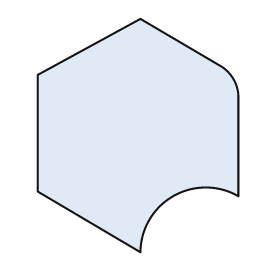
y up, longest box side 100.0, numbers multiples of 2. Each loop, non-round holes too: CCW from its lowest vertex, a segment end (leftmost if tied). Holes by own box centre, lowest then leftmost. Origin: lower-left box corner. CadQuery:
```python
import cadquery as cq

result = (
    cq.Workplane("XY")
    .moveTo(44.0, 0.0)
    .threePointArc((58.0, 24.0), (86.0, 24.0))
    .lineTo(86.0, 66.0)
    .threePointArc((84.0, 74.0), (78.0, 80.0))
    .lineTo(44.0, 100.0)
    .lineTo(0.0, 76.0)
    .lineTo(0.0, 26.0)
    .close()
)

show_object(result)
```